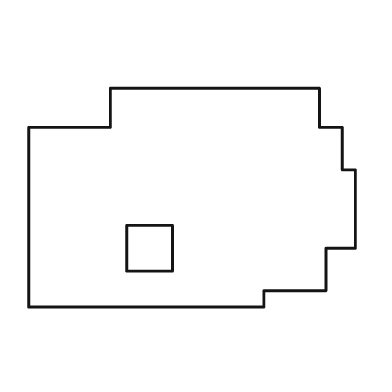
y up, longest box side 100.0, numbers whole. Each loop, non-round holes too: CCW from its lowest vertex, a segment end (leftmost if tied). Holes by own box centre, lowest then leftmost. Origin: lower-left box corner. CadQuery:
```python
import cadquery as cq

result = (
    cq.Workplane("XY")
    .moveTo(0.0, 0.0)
    .lineTo(72.0, 0.0)
    .lineTo(72.0, 5.0)
    .lineTo(91.0, 5.0)
    .lineTo(91.0, 18.0)
    .lineTo(100.0, 18.0)
    .lineTo(100.0, 42.0)
    .lineTo(96.0, 42.0)
    .lineTo(96.0, 55.0)
    .lineTo(89.0, 55.0)
    .lineTo(89.0, 67.0)
    .lineTo(25.0, 67.0)
    .lineTo(25.0, 55.0)
    .lineTo(0.0, 55.0)
    .close()
    .moveTo(30.0, 11.0)
    .lineTo(44.0, 11.0)
    .lineTo(44.0, 25.0)
    .lineTo(30.0, 25.0)
    .close()
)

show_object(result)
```